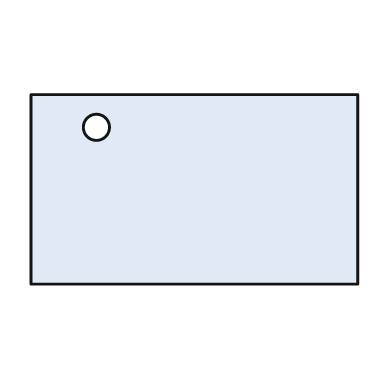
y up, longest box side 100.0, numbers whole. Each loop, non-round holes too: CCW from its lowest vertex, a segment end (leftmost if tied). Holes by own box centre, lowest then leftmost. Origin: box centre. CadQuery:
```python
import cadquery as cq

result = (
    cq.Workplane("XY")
    .moveTo(-50.0, -29.0)
    .lineTo(50.0, -29.0)
    .lineTo(50.0, 29.0)
    .lineTo(-50.0, 29.0)
    .close()
    .moveTo(-30.0, 19.0)
    .circle(4.0)
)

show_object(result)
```